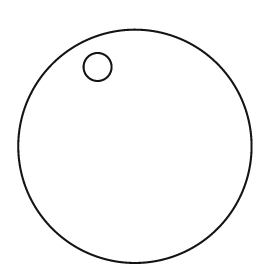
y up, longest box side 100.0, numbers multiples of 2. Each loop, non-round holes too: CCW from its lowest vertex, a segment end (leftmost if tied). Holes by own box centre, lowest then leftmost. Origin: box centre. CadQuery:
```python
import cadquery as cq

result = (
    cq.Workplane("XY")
    .moveTo(0.0, 0.0)
    .circle(50.0)
    .moveTo(-16.0, 34.0)
    .circle(6.0)
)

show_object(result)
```